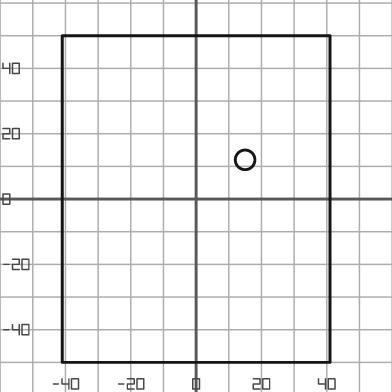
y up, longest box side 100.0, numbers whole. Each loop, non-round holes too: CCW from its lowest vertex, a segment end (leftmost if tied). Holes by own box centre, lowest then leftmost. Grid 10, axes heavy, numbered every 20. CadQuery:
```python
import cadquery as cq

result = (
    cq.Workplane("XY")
    .moveTo(-41.0, -50.0)
    .lineTo(41.0, -50.0)
    .lineTo(41.0, 50.0)
    .lineTo(-41.0, 50.0)
    .close()
    .moveTo(15.0, 12.0)
    .circle(3.0)
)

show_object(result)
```